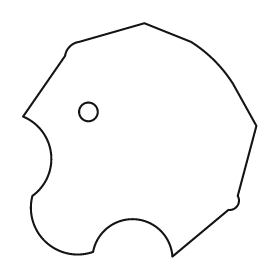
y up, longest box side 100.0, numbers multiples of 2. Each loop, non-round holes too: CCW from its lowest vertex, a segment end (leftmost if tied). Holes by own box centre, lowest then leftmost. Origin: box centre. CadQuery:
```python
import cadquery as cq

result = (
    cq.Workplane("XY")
    .moveTo(14.0, -50.0)
    .lineTo(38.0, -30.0)
    .threePointArc((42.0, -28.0), (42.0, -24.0))
    .lineTo(50.0, 6.0)
    .lineTo(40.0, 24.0)
    .threePointArc((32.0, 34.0), (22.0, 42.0))
    .lineTo(2.0, 50.0)
    .lineTo(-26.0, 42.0)
    .threePointArc((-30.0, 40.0), (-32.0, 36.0))
    .lineTo(-50.0, 10.0)
    .threePointArc((-38.0, -6.0), (-46.0, -24.0))
    .threePointArc((-40.0, -44.0), (-20.0, -48.0))
    .threePointArc((-2.0, -34.0), (14.0, -50.0))
    .close()
    .moveTo(-22.0, 12.0)
    .circle(4.0)
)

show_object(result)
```